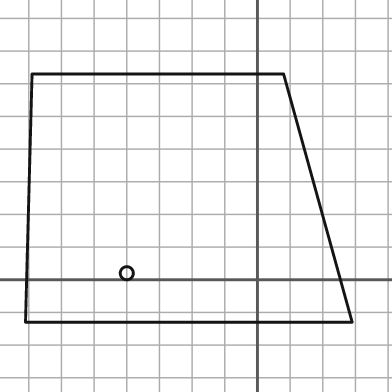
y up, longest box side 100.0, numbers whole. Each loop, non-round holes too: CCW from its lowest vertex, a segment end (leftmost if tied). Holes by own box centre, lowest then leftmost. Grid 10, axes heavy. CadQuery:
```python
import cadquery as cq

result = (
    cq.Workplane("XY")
    .moveTo(-71.0, -13.0)
    .lineTo(29.0, -13.0)
    .lineTo(8.0, 63.0)
    .lineTo(-69.0, 63.0)
    .close()
    .moveTo(-40.0, 2.0)
    .circle(2.0)
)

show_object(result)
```